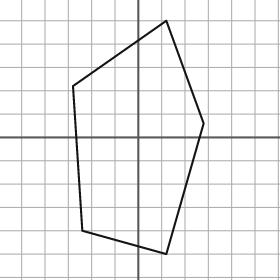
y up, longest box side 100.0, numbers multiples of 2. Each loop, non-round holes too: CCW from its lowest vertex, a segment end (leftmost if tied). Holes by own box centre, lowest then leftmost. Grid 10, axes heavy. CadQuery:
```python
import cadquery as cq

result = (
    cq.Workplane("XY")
    .moveTo(12.0, -50.0)
    .lineTo(28.0, 6.0)
    .lineTo(12.0, 50.0)
    .lineTo(-28.0, 22.0)
    .lineTo(-24.0, -40.0)
    .close()
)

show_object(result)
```